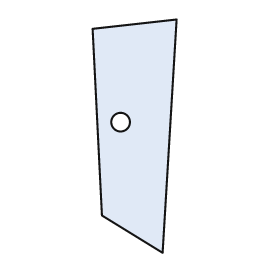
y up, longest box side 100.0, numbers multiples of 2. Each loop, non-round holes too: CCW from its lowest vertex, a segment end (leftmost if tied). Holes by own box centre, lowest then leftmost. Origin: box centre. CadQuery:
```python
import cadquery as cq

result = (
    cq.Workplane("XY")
    .moveTo(12.0, -50.0)
    .lineTo(18.0, 50.0)
    .lineTo(-18.0, 46.0)
    .lineTo(-14.0, -34.0)
    .close()
    .moveTo(-6.0, 6.0)
    .circle(4.0)
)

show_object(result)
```